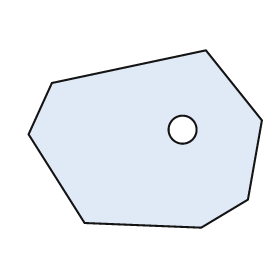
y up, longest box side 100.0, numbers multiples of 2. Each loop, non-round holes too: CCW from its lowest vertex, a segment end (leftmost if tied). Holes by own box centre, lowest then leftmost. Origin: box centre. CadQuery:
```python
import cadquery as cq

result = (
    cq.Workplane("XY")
    .moveTo(24.0, -38.0)
    .lineTo(44.0, -26.0)
    .lineTo(50.0, 8.0)
    .lineTo(26.0, 38.0)
    .lineTo(-40.0, 24.0)
    .lineTo(-50.0, 2.0)
    .lineTo(-26.0, -36.0)
    .close()
    .moveTo(16.0, 4.0)
    .circle(6.0)
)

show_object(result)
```